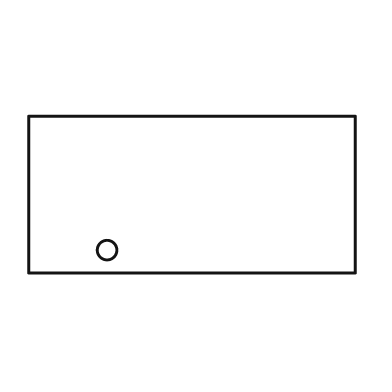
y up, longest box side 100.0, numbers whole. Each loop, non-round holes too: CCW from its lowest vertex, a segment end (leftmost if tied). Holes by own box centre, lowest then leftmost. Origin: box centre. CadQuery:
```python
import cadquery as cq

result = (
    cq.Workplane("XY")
    .moveTo(-50.0, -24.0)
    .lineTo(50.0, -24.0)
    .lineTo(50.0, 24.0)
    .lineTo(-50.0, 24.0)
    .close()
    .moveTo(-26.0, -17.0)
    .circle(3.0)
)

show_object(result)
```